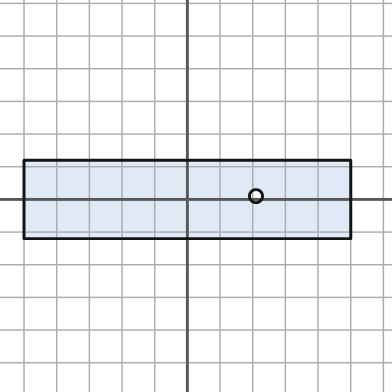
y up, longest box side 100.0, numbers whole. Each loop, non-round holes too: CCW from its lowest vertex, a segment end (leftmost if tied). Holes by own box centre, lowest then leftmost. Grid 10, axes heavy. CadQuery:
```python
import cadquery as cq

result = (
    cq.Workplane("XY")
    .moveTo(-50.0, -12.0)
    .lineTo(50.0, -12.0)
    .lineTo(50.0, 12.0)
    .lineTo(-50.0, 12.0)
    .close()
    .moveTo(21.0, 1.0)
    .circle(2.0)
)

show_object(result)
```